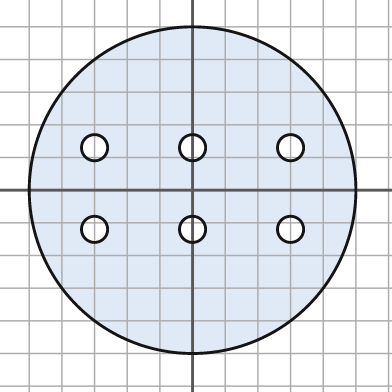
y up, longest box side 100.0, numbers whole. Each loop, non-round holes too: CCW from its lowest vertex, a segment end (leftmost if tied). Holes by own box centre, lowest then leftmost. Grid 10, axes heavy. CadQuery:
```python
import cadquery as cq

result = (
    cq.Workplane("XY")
    .moveTo(0.0, 0.0)
    .circle(50.0)
    .moveTo(-30.0, -12.0)
    .circle(4.0)
    .moveTo(0.0, -12.0)
    .circle(4.0)
    .moveTo(30.0, -12.0)
    .circle(4.0)
    .moveTo(-30.0, 13.0)
    .circle(4.0)
    .moveTo(0.0, 13.0)
    .circle(4.0)
    .moveTo(30.0, 13.0)
    .circle(4.0)
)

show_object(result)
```